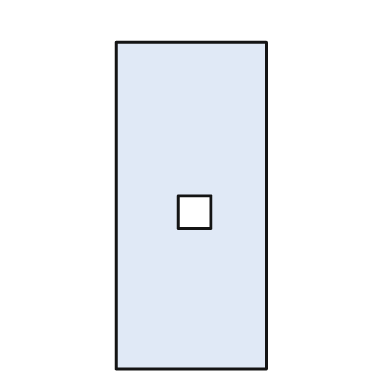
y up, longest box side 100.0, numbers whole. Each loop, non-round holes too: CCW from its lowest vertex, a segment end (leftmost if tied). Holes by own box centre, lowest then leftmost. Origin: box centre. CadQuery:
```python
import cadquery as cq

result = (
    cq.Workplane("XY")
    .moveTo(-23.0, -50.0)
    .lineTo(23.0, -50.0)
    .lineTo(23.0, 50.0)
    .lineTo(-23.0, 50.0)
    .close()
    .moveTo(-4.0, -7.0)
    .lineTo(6.0, -7.0)
    .lineTo(6.0, 3.0)
    .lineTo(-4.0, 3.0)
    .close()
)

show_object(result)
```